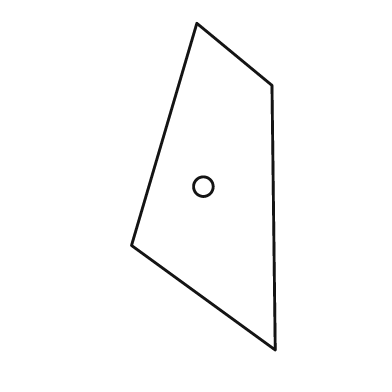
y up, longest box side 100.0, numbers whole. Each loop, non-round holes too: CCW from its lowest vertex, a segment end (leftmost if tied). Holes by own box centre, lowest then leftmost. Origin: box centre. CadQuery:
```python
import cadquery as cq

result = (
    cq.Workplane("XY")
    .moveTo(22.0, -50.0)
    .lineTo(21.0, 31.0)
    .lineTo(-2.0, 50.0)
    .lineTo(-22.0, -18.0)
    .close()
    .moveTo(0.0, 0.0)
    .circle(3.0)
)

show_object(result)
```